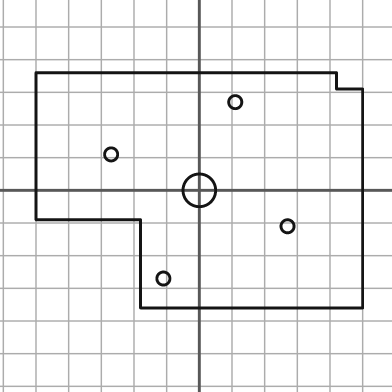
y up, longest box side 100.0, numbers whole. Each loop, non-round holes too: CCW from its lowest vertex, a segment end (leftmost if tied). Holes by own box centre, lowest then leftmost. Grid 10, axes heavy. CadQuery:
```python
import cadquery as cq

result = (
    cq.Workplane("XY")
    .moveTo(-18.0, -36.0)
    .lineTo(50.0, -36.0)
    .lineTo(50.0, 31.0)
    .lineTo(42.0, 31.0)
    .lineTo(42.0, 36.0)
    .lineTo(-50.0, 36.0)
    .lineTo(-50.0, -9.0)
    .lineTo(-18.0, -9.0)
    .close()
    .moveTo(-11.0, -27.0)
    .circle(2.0)
    .moveTo(27.0, -11.0)
    .circle(2.0)
    .moveTo(0.0, 0.0)
    .circle(5.0)
    .moveTo(-27.0, 11.0)
    .circle(2.0)
    .moveTo(11.0, 27.0)
    .circle(2.0)
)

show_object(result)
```